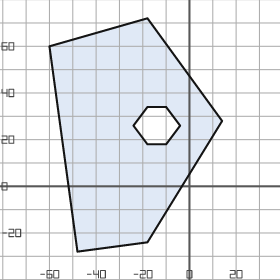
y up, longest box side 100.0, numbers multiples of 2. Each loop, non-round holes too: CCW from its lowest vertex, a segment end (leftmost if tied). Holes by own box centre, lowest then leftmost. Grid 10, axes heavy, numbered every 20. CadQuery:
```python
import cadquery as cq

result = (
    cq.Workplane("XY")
    .moveTo(-48.0, -28.0)
    .lineTo(-18.0, -24.0)
    .lineTo(14.0, 28.0)
    .lineTo(-18.0, 72.0)
    .lineTo(-60.0, 60.0)
    .close()
    .moveTo(-18.0, 18.0)
    .lineTo(-10.0, 18.0)
    .lineTo(-4.0, 26.0)
    .lineTo(-10.0, 34.0)
    .lineTo(-18.0, 34.0)
    .lineTo(-24.0, 26.0)
    .close()
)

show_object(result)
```